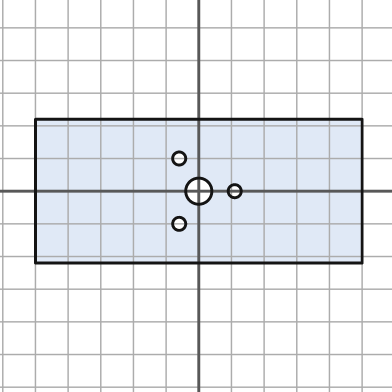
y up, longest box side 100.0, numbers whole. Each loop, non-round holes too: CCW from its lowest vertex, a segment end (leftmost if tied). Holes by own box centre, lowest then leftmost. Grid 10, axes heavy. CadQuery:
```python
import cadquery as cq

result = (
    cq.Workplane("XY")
    .moveTo(-50.0, -22.0)
    .lineTo(50.0, -22.0)
    .lineTo(50.0, 22.0)
    .lineTo(-50.0, 22.0)
    .close()
    .moveTo(-6.0, -10.0)
    .circle(2.0)
    .moveTo(0.0, 0.0)
    .circle(4.0)
    .moveTo(11.0, 0.0)
    .circle(2.0)
    .moveTo(-6.0, 10.0)
    .circle(2.0)
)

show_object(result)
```